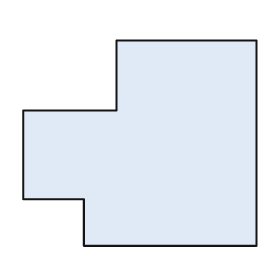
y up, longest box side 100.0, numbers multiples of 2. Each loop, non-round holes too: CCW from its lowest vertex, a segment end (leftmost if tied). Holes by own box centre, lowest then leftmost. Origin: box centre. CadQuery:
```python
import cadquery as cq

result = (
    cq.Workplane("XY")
    .moveTo(-24.0, -44.0)
    .lineTo(50.0, -44.0)
    .lineTo(50.0, 44.0)
    .lineTo(-10.0, 44.0)
    .lineTo(-10.0, 14.0)
    .lineTo(-50.0, 14.0)
    .lineTo(-50.0, -24.0)
    .lineTo(-24.0, -24.0)
    .close()
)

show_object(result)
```